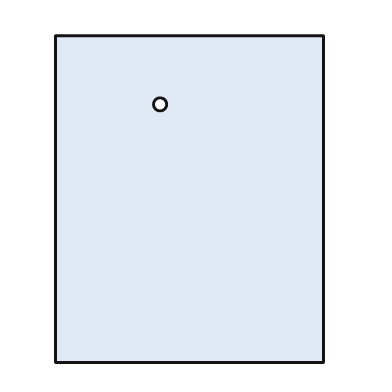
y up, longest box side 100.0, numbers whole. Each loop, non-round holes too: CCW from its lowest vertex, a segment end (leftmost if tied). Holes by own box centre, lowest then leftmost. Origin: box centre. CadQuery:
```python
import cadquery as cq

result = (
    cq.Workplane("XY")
    .moveTo(-41.0, -50.0)
    .lineTo(41.0, -50.0)
    .lineTo(41.0, 50.0)
    .lineTo(-41.0, 50.0)
    .close()
    .moveTo(-9.0, 29.0)
    .circle(2.0)
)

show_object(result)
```